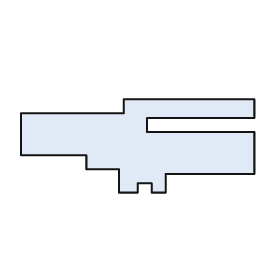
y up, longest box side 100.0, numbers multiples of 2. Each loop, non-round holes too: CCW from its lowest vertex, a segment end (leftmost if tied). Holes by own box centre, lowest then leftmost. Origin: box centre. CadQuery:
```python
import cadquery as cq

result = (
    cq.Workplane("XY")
    .moveTo(-8.0, -20.0)
    .lineTo(0.0, -20.0)
    .lineTo(0.0, -16.0)
    .lineTo(6.0, -16.0)
    .lineTo(6.0, -20.0)
    .lineTo(12.0, -20.0)
    .lineTo(12.0, -12.0)
    .lineTo(50.0, -12.0)
    .lineTo(50.0, 6.0)
    .lineTo(4.0, 6.0)
    .lineTo(4.0, 12.0)
    .lineTo(50.0, 12.0)
    .lineTo(50.0, 20.0)
    .lineTo(-6.0, 20.0)
    .lineTo(-6.0, 14.0)
    .lineTo(-50.0, 14.0)
    .lineTo(-50.0, -4.0)
    .lineTo(-22.0, -4.0)
    .lineTo(-22.0, -10.0)
    .lineTo(-8.0, -10.0)
    .close()
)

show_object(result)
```